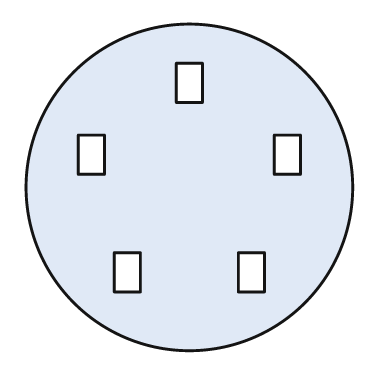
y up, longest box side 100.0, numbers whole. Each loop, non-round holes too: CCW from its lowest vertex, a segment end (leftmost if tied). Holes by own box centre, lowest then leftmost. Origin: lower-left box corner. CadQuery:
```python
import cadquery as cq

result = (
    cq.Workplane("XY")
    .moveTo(50.0, 50.0)
    .circle(50.0)
    .moveTo(27.0, 18.0)
    .lineTo(35.0, 18.0)
    .lineTo(35.0, 30.0)
    .lineTo(27.0, 30.0)
    .close()
    .moveTo(65.0, 18.0)
    .lineTo(73.0, 18.0)
    .lineTo(73.0, 30.0)
    .lineTo(65.0, 30.0)
    .close()
    .moveTo(16.0, 54.0)
    .lineTo(24.0, 54.0)
    .lineTo(24.0, 66.0)
    .lineTo(16.0, 66.0)
    .close()
    .moveTo(76.0, 54.0)
    .lineTo(84.0, 54.0)
    .lineTo(84.0, 66.0)
    .lineTo(76.0, 66.0)
    .close()
    .moveTo(46.0, 76.0)
    .lineTo(54.0, 76.0)
    .lineTo(54.0, 88.0)
    .lineTo(46.0, 88.0)
    .close()
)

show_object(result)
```